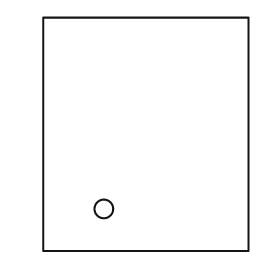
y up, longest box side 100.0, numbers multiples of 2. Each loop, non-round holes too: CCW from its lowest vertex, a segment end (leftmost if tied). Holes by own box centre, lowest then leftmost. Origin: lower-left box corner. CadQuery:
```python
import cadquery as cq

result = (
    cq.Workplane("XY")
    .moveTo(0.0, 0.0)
    .lineTo(88.0, 0.0)
    .lineTo(88.0, 100.0)
    .lineTo(0.0, 100.0)
    .close()
    .moveTo(26.0, 18.0)
    .circle(4.0)
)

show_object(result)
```